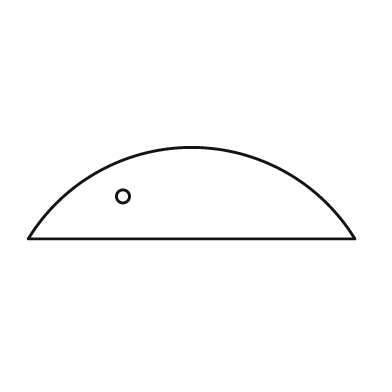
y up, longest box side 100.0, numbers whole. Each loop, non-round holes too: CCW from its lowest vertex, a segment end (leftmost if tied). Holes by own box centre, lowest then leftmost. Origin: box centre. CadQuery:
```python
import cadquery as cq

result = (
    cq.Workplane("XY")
    .moveTo(-50.0, -14.0)
    .lineTo(50.0, -14.0)
    .threePointArc((0.0, 14.0), (-50.0, -14.0))
    .close()
    .moveTo(-21.0, -1.0)
    .circle(2.0)
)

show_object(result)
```